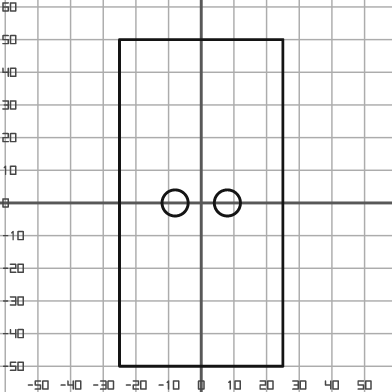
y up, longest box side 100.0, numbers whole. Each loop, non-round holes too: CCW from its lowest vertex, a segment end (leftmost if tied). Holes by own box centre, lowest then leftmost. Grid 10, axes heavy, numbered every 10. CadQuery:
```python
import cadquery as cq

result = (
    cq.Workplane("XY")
    .moveTo(-25.0, -50.0)
    .lineTo(25.0, -50.0)
    .lineTo(25.0, 50.0)
    .lineTo(-25.0, 50.0)
    .close()
    .moveTo(-8.0, 0.0)
    .circle(4.0)
    .moveTo(8.0, 0.0)
    .circle(4.0)
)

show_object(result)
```